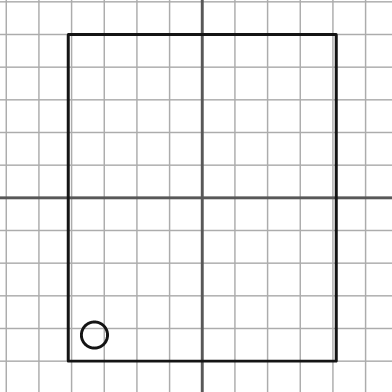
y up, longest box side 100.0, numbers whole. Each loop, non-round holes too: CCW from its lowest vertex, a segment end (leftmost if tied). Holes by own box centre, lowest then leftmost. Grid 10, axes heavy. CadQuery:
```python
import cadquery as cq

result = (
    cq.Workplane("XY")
    .moveTo(-41.0, -50.0)
    .lineTo(41.0, -50.0)
    .lineTo(41.0, 50.0)
    .lineTo(-41.0, 50.0)
    .close()
    .moveTo(-33.0, -42.0)
    .circle(4.0)
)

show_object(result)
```